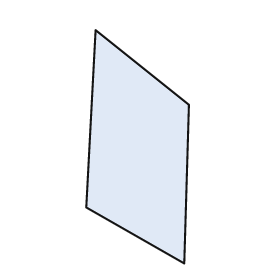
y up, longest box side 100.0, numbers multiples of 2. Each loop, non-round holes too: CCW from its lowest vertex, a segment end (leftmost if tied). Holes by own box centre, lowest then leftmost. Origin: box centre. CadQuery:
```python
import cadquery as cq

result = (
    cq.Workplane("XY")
    .moveTo(20.0, -50.0)
    .lineTo(22.0, 18.0)
    .lineTo(-18.0, 50.0)
    .lineTo(-22.0, -26.0)
    .close()
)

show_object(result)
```